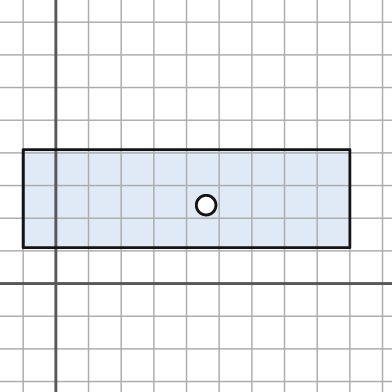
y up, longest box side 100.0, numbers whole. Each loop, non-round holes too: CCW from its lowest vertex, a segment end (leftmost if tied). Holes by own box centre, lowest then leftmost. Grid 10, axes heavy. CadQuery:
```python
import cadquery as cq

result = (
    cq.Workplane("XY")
    .moveTo(-10.0, 11.0)
    .lineTo(90.0, 11.0)
    .lineTo(90.0, 41.0)
    .lineTo(-10.0, 41.0)
    .close()
    .moveTo(46.0, 24.0)
    .circle(3.0)
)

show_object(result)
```